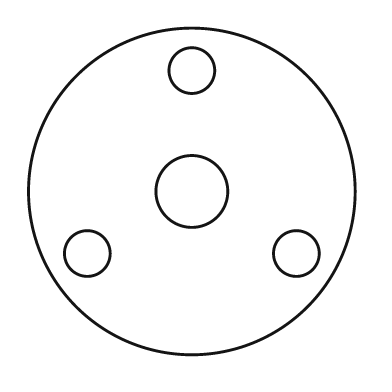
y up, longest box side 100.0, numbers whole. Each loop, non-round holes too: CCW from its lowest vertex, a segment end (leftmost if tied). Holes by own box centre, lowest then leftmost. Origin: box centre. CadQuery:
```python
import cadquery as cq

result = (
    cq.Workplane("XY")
    .moveTo(0.0, 0.0)
    .circle(50.0)
    .moveTo(-32.0, -19.0)
    .circle(7.0)
    .moveTo(32.0, -19.0)
    .circle(7.0)
    .moveTo(0.0, 0.0)
    .circle(11.0)
    .moveTo(0.0, 37.0)
    .circle(7.0)
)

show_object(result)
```